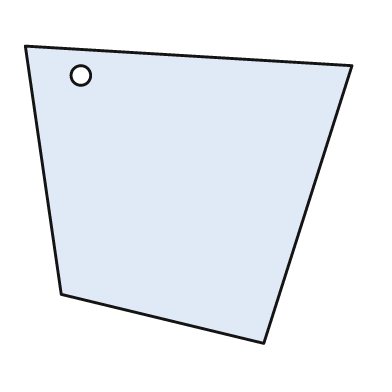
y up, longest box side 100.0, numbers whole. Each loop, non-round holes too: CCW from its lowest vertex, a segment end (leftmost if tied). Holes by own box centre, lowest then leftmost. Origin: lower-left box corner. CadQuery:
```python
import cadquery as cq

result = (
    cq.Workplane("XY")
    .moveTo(73.0, 0.0)
    .lineTo(100.0, 85.0)
    .lineTo(0.0, 91.0)
    .lineTo(11.0, 15.0)
    .close()
    .moveTo(17.0, 82.0)
    .circle(3.0)
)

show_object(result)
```